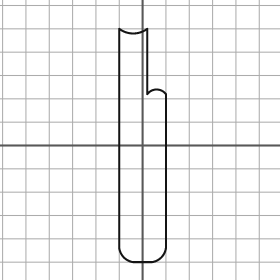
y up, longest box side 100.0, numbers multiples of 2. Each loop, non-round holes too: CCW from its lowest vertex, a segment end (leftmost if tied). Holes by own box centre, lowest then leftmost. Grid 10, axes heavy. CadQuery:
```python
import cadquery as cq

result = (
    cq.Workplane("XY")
    .moveTo(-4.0, -50.0)
    .lineTo(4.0, -50.0)
    .threePointArc((8.0, -48.0), (10.0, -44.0))
    .lineTo(10.0, 22.0)
    .threePointArc((6.0, 24.0), (2.0, 22.0))
    .lineTo(2.0, 50.0)
    .threePointArc((-4.0, 48.0), (-10.0, 50.0))
    .lineTo(-10.0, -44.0)
    .threePointArc((-8.0, -48.0), (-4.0, -50.0))
    .close()
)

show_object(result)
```